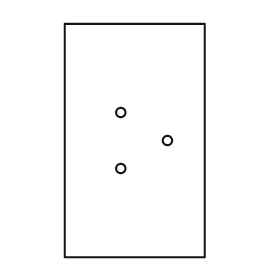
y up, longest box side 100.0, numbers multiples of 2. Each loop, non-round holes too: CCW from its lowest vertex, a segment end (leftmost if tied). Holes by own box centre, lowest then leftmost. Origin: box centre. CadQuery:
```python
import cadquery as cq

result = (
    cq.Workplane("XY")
    .moveTo(-30.0, -50.0)
    .lineTo(30.0, -50.0)
    .lineTo(30.0, 50.0)
    .lineTo(-30.0, 50.0)
    .close()
    .moveTo(-6.0, -12.0)
    .circle(2.0)
    .moveTo(14.0, 0.0)
    .circle(2.0)
    .moveTo(-6.0, 12.0)
    .circle(2.0)
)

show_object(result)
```